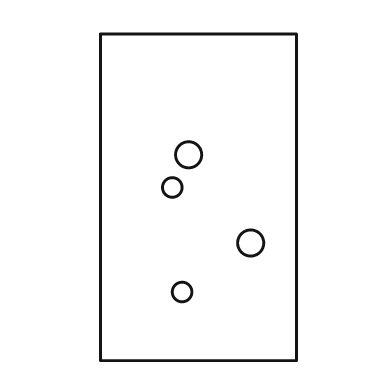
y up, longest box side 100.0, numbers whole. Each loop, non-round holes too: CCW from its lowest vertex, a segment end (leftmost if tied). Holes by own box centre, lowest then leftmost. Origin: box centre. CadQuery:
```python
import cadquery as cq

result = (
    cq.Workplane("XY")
    .moveTo(-30.0, -50.0)
    .lineTo(30.0, -50.0)
    .lineTo(30.0, 50.0)
    .lineTo(-30.0, 50.0)
    .close()
    .moveTo(-5.0, -29.0)
    .circle(3.0)
    .moveTo(16.0, -14.0)
    .circle(4.0)
    .moveTo(-8.0, 3.0)
    .circle(3.0)
    .moveTo(-3.0, 13.0)
    .circle(4.0)
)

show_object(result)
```